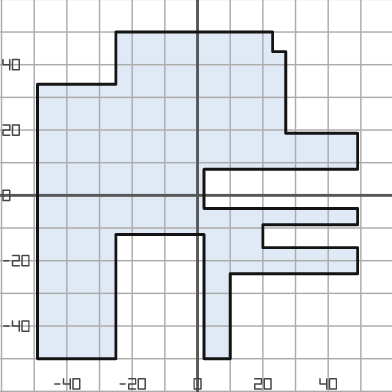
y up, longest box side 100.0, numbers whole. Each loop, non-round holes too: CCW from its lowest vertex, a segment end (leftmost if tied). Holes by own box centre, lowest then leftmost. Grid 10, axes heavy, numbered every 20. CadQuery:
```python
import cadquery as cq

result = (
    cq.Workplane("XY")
    .moveTo(-49.0, -50.0)
    .lineTo(-25.0, -50.0)
    .lineTo(-25.0, -12.0)
    .lineTo(2.0, -12.0)
    .lineTo(2.0, -50.0)
    .lineTo(10.0, -50.0)
    .lineTo(10.0, -24.0)
    .lineTo(49.0, -24.0)
    .lineTo(49.0, -16.0)
    .lineTo(20.0, -16.0)
    .lineTo(20.0, -9.0)
    .lineTo(49.0, -9.0)
    .lineTo(49.0, -4.0)
    .lineTo(2.0, -4.0)
    .lineTo(2.0, 8.0)
    .lineTo(49.0, 8.0)
    .lineTo(49.0, 19.0)
    .lineTo(27.0, 19.0)
    .lineTo(27.0, 44.0)
    .lineTo(23.0, 44.0)
    .lineTo(23.0, 50.0)
    .lineTo(-25.0, 50.0)
    .lineTo(-25.0, 34.0)
    .lineTo(-49.0, 34.0)
    .close()
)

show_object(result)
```